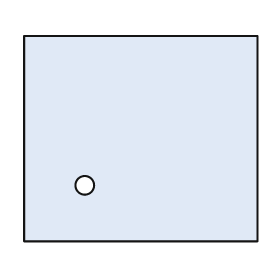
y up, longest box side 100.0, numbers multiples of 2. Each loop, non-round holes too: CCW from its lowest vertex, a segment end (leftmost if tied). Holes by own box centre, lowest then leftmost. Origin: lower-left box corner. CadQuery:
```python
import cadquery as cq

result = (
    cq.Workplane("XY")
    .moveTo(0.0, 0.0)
    .lineTo(100.0, 0.0)
    .lineTo(100.0, 88.0)
    .lineTo(0.0, 88.0)
    .close()
    .moveTo(26.0, 24.0)
    .circle(4.0)
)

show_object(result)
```